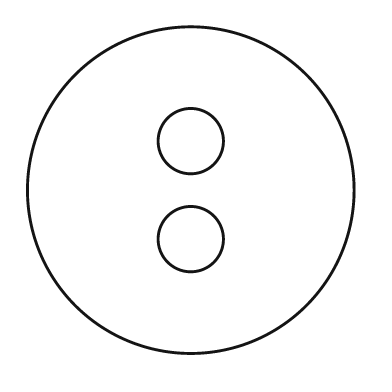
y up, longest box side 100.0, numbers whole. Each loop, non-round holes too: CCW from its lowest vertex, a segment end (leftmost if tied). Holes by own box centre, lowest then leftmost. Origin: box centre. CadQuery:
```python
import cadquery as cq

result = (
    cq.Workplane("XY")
    .moveTo(0.0, 0.0)
    .circle(50.0)
    .moveTo(0.0, -15.0)
    .circle(10.0)
    .moveTo(0.0, 15.0)
    .circle(10.0)
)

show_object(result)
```